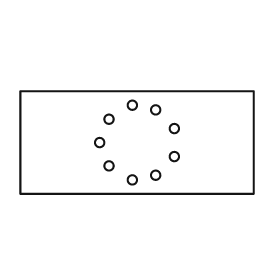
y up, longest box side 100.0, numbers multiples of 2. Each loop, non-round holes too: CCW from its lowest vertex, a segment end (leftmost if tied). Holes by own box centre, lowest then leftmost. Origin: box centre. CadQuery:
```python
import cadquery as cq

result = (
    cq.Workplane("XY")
    .moveTo(-50.0, -22.0)
    .lineTo(50.0, -22.0)
    .lineTo(50.0, 22.0)
    .lineTo(-50.0, 22.0)
    .close()
    .moveTo(-2.0, -16.0)
    .circle(2.0)
    .moveTo(8.0, -14.0)
    .circle(2.0)
    .moveTo(-12.0, -10.0)
    .circle(2.0)
    .moveTo(16.0, -6.0)
    .circle(2.0)
    .moveTo(-16.0, 0.0)
    .circle(2.0)
    .moveTo(16.0, 6.0)
    .circle(2.0)
    .moveTo(-12.0, 10.0)
    .circle(2.0)
    .moveTo(8.0, 14.0)
    .circle(2.0)
    .moveTo(-2.0, 16.0)
    .circle(2.0)
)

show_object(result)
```